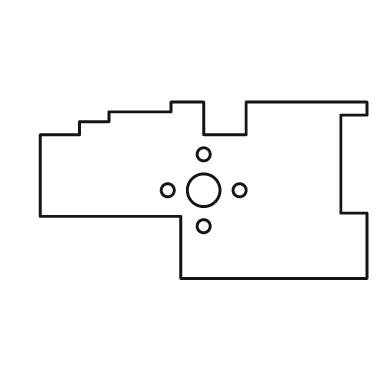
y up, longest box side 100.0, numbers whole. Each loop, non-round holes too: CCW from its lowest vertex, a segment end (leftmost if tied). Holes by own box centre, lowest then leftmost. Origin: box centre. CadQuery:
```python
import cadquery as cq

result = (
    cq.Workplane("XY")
    .moveTo(-7.0, -27.0)
    .lineTo(50.0, -27.0)
    .lineTo(50.0, -7.0)
    .lineTo(42.0, -7.0)
    .lineTo(42.0, 23.0)
    .lineTo(50.0, 23.0)
    .lineTo(50.0, 27.0)
    .lineTo(13.0, 27.0)
    .lineTo(13.0, 17.0)
    .lineTo(0.0, 17.0)
    .lineTo(0.0, 27.0)
    .lineTo(-10.0, 27.0)
    .lineTo(-10.0, 24.0)
    .lineTo(-29.0, 24.0)
    .lineTo(-29.0, 21.0)
    .lineTo(-38.0, 21.0)
    .lineTo(-38.0, 17.0)
    .lineTo(-50.0, 17.0)
    .lineTo(-50.0, -8.0)
    .lineTo(-7.0, -8.0)
    .close()
    .moveTo(0.0, -11.0)
    .circle(2.0)
    .moveTo(-11.0, 0.0)
    .circle(2.0)
    .moveTo(0.0, 0.0)
    .circle(5.0)
    .moveTo(11.0, 0.0)
    .circle(2.0)
    .moveTo(0.0, 11.0)
    .circle(2.0)
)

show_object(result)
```